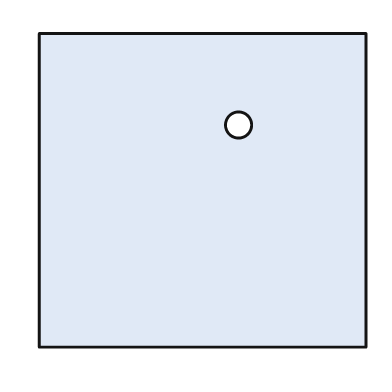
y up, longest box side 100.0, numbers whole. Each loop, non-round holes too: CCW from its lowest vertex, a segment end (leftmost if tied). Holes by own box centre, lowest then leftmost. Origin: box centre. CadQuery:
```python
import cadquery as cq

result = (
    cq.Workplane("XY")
    .moveTo(-50.0, -48.0)
    .lineTo(50.0, -48.0)
    .lineTo(50.0, 48.0)
    .lineTo(-50.0, 48.0)
    .close()
    .moveTo(11.0, 20.0)
    .circle(4.0)
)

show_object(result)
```